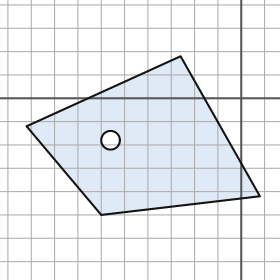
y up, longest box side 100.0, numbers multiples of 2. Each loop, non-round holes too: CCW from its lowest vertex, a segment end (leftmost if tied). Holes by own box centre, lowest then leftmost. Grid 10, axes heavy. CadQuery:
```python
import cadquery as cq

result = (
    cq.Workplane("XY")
    .moveTo(-60.0, -50.0)
    .lineTo(8.0, -42.0)
    .lineTo(-26.0, 18.0)
    .lineTo(-92.0, -12.0)
    .close()
    .moveTo(-56.0, -18.0)
    .circle(4.0)
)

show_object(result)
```